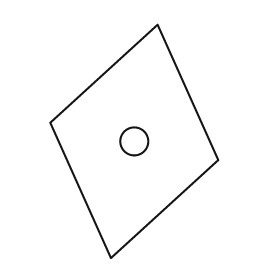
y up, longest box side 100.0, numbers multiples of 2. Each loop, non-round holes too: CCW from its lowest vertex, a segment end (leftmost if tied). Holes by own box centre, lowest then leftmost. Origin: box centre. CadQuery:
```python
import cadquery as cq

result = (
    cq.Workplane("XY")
    .moveTo(-10.0, -50.0)
    .lineTo(36.0, -8.0)
    .lineTo(10.0, 50.0)
    .lineTo(-36.0, 8.0)
    .close()
    .moveTo(0.0, 0.0)
    .circle(6.0)
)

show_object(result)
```